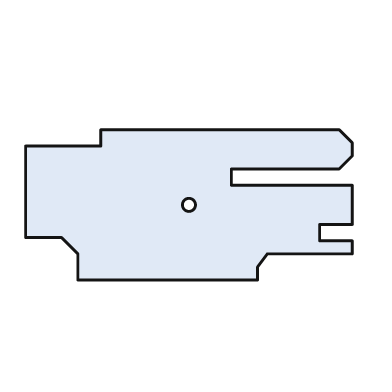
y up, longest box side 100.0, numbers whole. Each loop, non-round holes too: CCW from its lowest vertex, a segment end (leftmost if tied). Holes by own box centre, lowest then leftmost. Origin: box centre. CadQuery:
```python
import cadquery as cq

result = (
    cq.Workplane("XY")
    .moveTo(-34.0, -23.0)
    .lineTo(21.0, -23.0)
    .lineTo(21.0, -19.0)
    .lineTo(24.0, -15.0)
    .lineTo(50.0, -15.0)
    .lineTo(50.0, -11.0)
    .lineTo(40.0, -11.0)
    .lineTo(40.0, -6.0)
    .lineTo(50.0, -6.0)
    .lineTo(50.0, 6.0)
    .lineTo(13.0, 6.0)
    .lineTo(13.0, 11.0)
    .lineTo(46.0, 11.0)
    .lineTo(50.0, 15.0)
    .lineTo(50.0, 19.0)
    .lineTo(46.0, 23.0)
    .lineTo(-27.0, 23.0)
    .lineTo(-27.0, 18.0)
    .lineTo(-50.0, 18.0)
    .lineTo(-50.0, -10.0)
    .lineTo(-39.0, -10.0)
    .lineTo(-34.0, -15.0)
    .close()
    .moveTo(0.0, 0.0)
    .circle(2.0)
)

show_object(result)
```